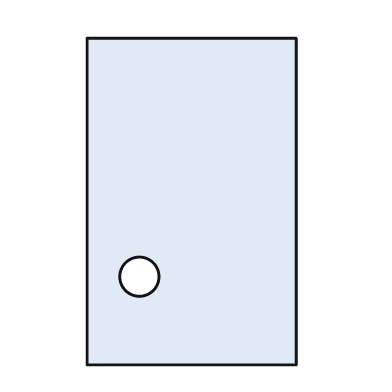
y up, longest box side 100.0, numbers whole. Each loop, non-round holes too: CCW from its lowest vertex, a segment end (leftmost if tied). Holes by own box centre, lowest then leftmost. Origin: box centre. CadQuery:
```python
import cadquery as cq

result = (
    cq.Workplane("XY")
    .moveTo(-32.0, -50.0)
    .lineTo(32.0, -50.0)
    .lineTo(32.0, 50.0)
    .lineTo(-32.0, 50.0)
    .close()
    .moveTo(-16.0, -23.0)
    .circle(6.0)
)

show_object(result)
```